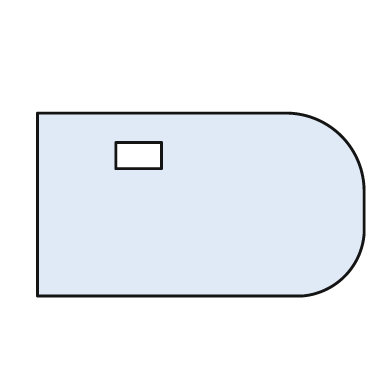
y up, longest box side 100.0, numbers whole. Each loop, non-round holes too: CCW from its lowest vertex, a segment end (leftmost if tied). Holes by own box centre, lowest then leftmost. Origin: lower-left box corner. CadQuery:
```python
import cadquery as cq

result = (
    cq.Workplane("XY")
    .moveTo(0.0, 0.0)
    .lineTo(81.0, 0.0)
    .threePointArc((94.0, 6.0), (100.0, 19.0))
    .lineTo(100.0, 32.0)
    .threePointArc((93.0, 49.0), (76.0, 56.0))
    .lineTo(0.0, 56.0)
    .close()
    .moveTo(24.0, 39.0)
    .lineTo(38.0, 39.0)
    .lineTo(38.0, 47.0)
    .lineTo(24.0, 47.0)
    .close()
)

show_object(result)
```